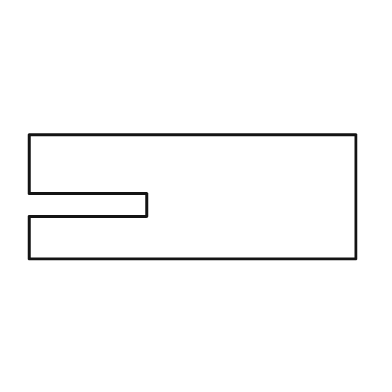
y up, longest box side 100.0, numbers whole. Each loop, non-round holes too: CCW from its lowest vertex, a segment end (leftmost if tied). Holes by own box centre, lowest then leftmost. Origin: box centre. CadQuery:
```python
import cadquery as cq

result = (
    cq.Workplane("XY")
    .moveTo(-50.0, -19.0)
    .lineTo(50.0, -19.0)
    .lineTo(50.0, 19.0)
    .lineTo(-50.0, 19.0)
    .lineTo(-50.0, 1.0)
    .lineTo(-14.0, 1.0)
    .lineTo(-14.0, -6.0)
    .lineTo(-50.0, -6.0)
    .close()
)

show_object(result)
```